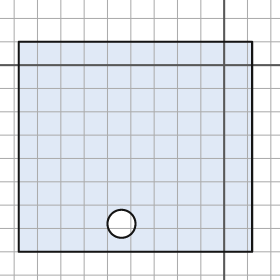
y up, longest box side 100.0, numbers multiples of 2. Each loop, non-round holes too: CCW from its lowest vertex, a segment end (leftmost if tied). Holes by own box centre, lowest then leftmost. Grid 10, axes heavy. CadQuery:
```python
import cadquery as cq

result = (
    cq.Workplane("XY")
    .moveTo(-88.0, -80.0)
    .lineTo(12.0, -80.0)
    .lineTo(12.0, 10.0)
    .lineTo(-88.0, 10.0)
    .close()
    .moveTo(-44.0, -68.0)
    .circle(6.0)
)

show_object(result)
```